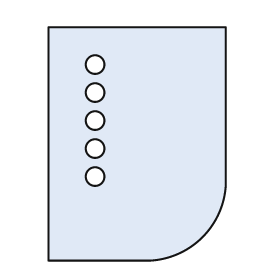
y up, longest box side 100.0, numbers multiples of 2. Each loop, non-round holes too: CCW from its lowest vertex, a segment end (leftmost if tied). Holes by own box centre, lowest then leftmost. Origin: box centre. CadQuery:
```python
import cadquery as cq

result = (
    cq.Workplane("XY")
    .moveTo(-38.0, -50.0)
    .lineTo(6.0, -50.0)
    .threePointArc((28.0, -40.0), (38.0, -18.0))
    .lineTo(38.0, 50.0)
    .lineTo(-38.0, 50.0)
    .close()
    .moveTo(-18.0, -14.0)
    .circle(4.0)
    .moveTo(-18.0, -2.0)
    .circle(4.0)
    .moveTo(-18.0, 10.0)
    .circle(4.0)
    .moveTo(-18.0, 22.0)
    .circle(4.0)
    .moveTo(-18.0, 34.0)
    .circle(4.0)
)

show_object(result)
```